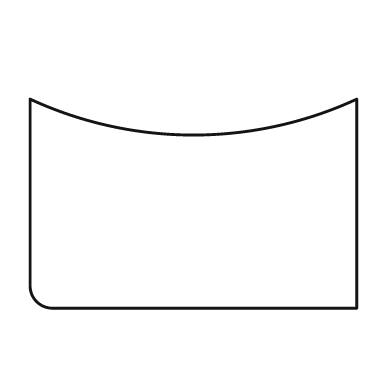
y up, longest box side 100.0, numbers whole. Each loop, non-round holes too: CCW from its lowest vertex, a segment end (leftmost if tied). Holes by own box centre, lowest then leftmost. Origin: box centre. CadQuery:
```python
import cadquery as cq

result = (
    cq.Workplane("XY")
    .moveTo(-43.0, -32.0)
    .lineTo(50.0, -32.0)
    .lineTo(50.0, 32.0)
    .threePointArc((0.0, 21.0), (-50.0, 32.0))
    .lineTo(-50.0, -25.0)
    .threePointArc((-48.0, -30.0), (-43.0, -32.0))
    .close()
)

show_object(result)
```